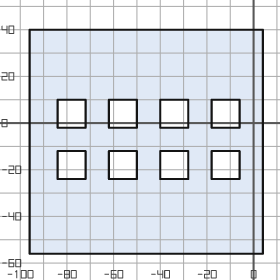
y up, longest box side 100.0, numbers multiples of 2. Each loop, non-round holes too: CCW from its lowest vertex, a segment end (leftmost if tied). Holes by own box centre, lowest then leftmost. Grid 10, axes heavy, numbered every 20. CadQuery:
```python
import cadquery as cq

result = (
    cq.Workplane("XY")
    .moveTo(-96.0, -56.0)
    .lineTo(4.0, -56.0)
    .lineTo(4.0, 40.0)
    .lineTo(-96.0, 40.0)
    .close()
    .moveTo(-84.0, -24.0)
    .lineTo(-72.0, -24.0)
    .lineTo(-72.0, -12.0)
    .lineTo(-84.0, -12.0)
    .close()
    .moveTo(-62.0, -24.0)
    .lineTo(-50.0, -24.0)
    .lineTo(-50.0, -12.0)
    .lineTo(-62.0, -12.0)
    .close()
    .moveTo(-40.0, -24.0)
    .lineTo(-28.0, -24.0)
    .lineTo(-28.0, -12.0)
    .lineTo(-40.0, -12.0)
    .close()
    .moveTo(-18.0, -24.0)
    .lineTo(-6.0, -24.0)
    .lineTo(-6.0, -12.0)
    .lineTo(-18.0, -12.0)
    .close()
    .moveTo(-84.0, -2.0)
    .lineTo(-72.0, -2.0)
    .lineTo(-72.0, 10.0)
    .lineTo(-84.0, 10.0)
    .close()
    .moveTo(-62.0, -2.0)
    .lineTo(-50.0, -2.0)
    .lineTo(-50.0, 10.0)
    .lineTo(-62.0, 10.0)
    .close()
    .moveTo(-40.0, -2.0)
    .lineTo(-28.0, -2.0)
    .lineTo(-28.0, 10.0)
    .lineTo(-40.0, 10.0)
    .close()
    .moveTo(-18.0, -2.0)
    .lineTo(-6.0, -2.0)
    .lineTo(-6.0, 10.0)
    .lineTo(-18.0, 10.0)
    .close()
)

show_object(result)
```